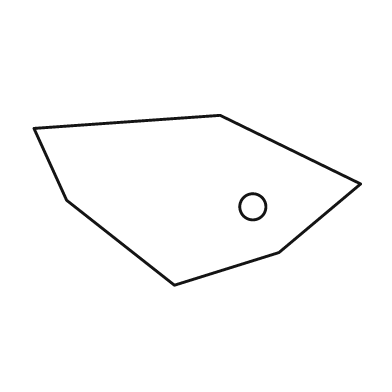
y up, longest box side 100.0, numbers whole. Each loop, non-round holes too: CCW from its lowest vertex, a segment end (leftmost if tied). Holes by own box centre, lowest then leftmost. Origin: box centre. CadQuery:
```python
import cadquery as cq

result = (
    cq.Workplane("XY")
    .moveTo(-7.0, -26.0)
    .lineTo(25.0, -16.0)
    .lineTo(50.0, 5.0)
    .lineTo(7.0, 26.0)
    .lineTo(-50.0, 22.0)
    .lineTo(-40.0, 0.0)
    .close()
    .moveTo(17.0, -2.0)
    .circle(4.0)
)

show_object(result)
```